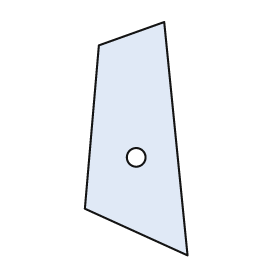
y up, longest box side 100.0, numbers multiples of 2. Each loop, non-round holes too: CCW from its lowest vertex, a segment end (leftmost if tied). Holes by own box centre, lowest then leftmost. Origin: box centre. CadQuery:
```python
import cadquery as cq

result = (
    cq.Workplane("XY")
    .moveTo(22.0, -50.0)
    .lineTo(12.0, 50.0)
    .lineTo(-16.0, 40.0)
    .lineTo(-22.0, -30.0)
    .close()
    .moveTo(0.0, -8.0)
    .circle(4.0)
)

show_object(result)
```